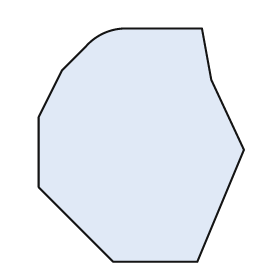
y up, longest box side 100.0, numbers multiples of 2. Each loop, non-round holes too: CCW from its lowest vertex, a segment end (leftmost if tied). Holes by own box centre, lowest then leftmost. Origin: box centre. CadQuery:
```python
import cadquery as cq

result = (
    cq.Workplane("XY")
    .moveTo(-12.0, -50.0)
    .lineTo(24.0, -50.0)
    .lineTo(44.0, -2.0)
    .lineTo(30.0, 28.0)
    .lineTo(26.0, 50.0)
    .lineTo(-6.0, 50.0)
    .threePointArc((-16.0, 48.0), (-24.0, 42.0))
    .lineTo(-34.0, 32.0)
    .lineTo(-44.0, 12.0)
    .lineTo(-44.0, -18.0)
    .close()
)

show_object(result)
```